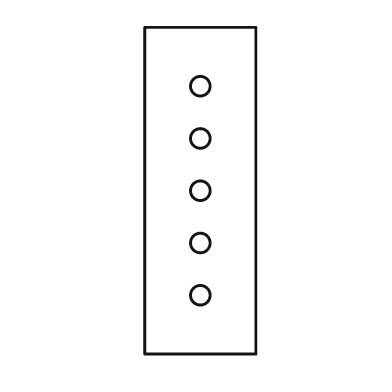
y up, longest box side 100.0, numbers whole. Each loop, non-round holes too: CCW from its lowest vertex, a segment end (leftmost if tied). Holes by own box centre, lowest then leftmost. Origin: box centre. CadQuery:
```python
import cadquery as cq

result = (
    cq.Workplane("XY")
    .moveTo(-17.0, -50.0)
    .lineTo(17.0, -50.0)
    .lineTo(17.0, 50.0)
    .lineTo(-17.0, 50.0)
    .close()
    .moveTo(0.0, -32.0)
    .circle(3.0)
    .moveTo(0.0, -16.0)
    .circle(3.0)
    .moveTo(0.0, 0.0)
    .circle(3.0)
    .moveTo(0.0, 16.0)
    .circle(3.0)
    .moveTo(0.0, 32.0)
    .circle(3.0)
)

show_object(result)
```